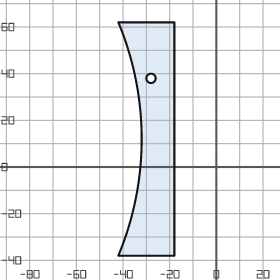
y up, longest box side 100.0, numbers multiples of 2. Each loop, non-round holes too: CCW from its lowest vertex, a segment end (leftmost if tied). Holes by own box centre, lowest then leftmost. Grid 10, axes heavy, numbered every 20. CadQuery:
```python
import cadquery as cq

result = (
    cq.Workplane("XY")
    .moveTo(-42.0, -38.0)
    .lineTo(-18.0, -38.0)
    .lineTo(-18.0, 62.0)
    .lineTo(-42.0, 62.0)
    .threePointArc((-32.0, 12.0), (-42.0, -38.0))
    .close()
    .moveTo(-28.0, 38.0)
    .circle(2.0)
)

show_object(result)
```